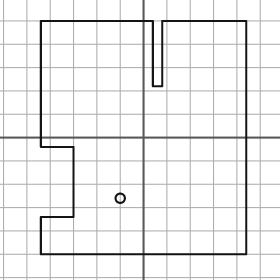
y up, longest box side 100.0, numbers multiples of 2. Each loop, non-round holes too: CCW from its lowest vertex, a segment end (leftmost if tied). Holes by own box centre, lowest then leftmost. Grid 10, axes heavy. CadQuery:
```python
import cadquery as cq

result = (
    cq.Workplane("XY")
    .moveTo(-44.0, -50.0)
    .lineTo(44.0, -50.0)
    .lineTo(44.0, 50.0)
    .lineTo(8.0, 50.0)
    .lineTo(8.0, 22.0)
    .lineTo(4.0, 22.0)
    .lineTo(4.0, 50.0)
    .lineTo(-44.0, 50.0)
    .lineTo(-44.0, -4.0)
    .lineTo(-30.0, -4.0)
    .lineTo(-30.0, -34.0)
    .lineTo(-44.0, -34.0)
    .close()
    .moveTo(-10.0, -26.0)
    .circle(2.0)
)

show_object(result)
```